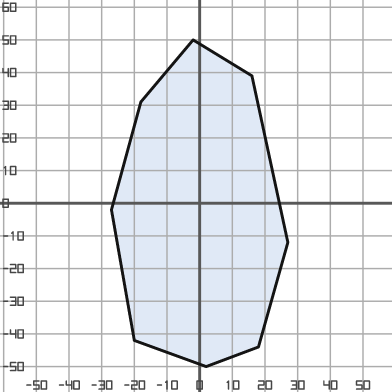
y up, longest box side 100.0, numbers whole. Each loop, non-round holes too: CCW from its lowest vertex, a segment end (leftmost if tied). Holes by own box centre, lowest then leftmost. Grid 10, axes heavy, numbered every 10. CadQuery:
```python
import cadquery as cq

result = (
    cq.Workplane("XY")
    .moveTo(2.0, -50.0)
    .lineTo(18.0, -44.0)
    .lineTo(27.0, -12.0)
    .lineTo(16.0, 39.0)
    .lineTo(-2.0, 50.0)
    .lineTo(-18.0, 31.0)
    .lineTo(-27.0, -2.0)
    .lineTo(-20.0, -42.0)
    .close()
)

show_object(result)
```